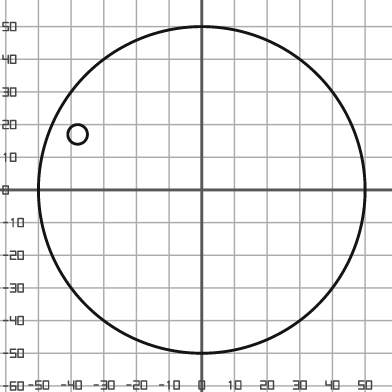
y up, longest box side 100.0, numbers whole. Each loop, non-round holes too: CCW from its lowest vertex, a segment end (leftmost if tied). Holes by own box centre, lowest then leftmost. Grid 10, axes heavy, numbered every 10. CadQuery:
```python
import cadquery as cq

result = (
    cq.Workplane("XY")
    .moveTo(0.0, 0.0)
    .circle(50.0)
    .moveTo(-38.0, 17.0)
    .circle(3.0)
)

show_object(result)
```